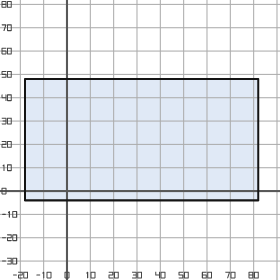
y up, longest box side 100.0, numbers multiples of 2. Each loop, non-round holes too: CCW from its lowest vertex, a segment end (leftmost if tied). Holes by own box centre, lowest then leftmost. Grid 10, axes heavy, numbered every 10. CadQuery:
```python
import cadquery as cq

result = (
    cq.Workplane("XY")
    .moveTo(-18.0, -4.0)
    .lineTo(82.0, -4.0)
    .lineTo(82.0, 48.0)
    .lineTo(-18.0, 48.0)
    .close()
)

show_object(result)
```